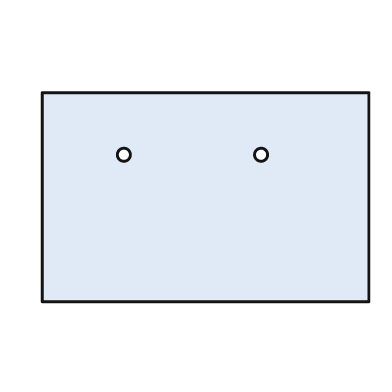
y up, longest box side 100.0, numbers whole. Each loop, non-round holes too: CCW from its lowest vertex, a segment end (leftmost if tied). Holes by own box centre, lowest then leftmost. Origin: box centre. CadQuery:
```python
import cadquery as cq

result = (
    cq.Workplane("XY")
    .moveTo(-50.0, -32.0)
    .lineTo(50.0, -32.0)
    .lineTo(50.0, 32.0)
    .lineTo(-50.0, 32.0)
    .close()
    .moveTo(-25.0, 13.0)
    .circle(2.0)
    .moveTo(17.0, 13.0)
    .circle(2.0)
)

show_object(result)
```